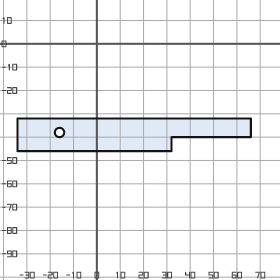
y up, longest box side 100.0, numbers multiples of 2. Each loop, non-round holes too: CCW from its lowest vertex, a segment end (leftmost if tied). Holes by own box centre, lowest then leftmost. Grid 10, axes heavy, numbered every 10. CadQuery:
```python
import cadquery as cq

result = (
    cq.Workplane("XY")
    .moveTo(-34.0, -46.0)
    .lineTo(32.0, -46.0)
    .lineTo(32.0, -40.0)
    .lineTo(66.0, -40.0)
    .lineTo(66.0, -32.0)
    .lineTo(-34.0, -32.0)
    .close()
    .moveTo(-16.0, -38.0)
    .circle(2.0)
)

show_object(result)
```